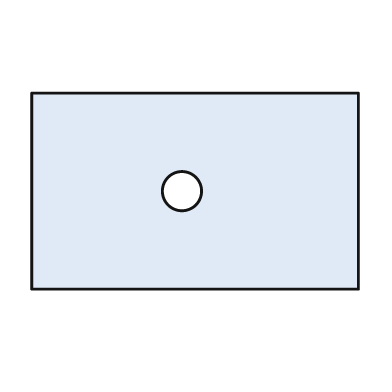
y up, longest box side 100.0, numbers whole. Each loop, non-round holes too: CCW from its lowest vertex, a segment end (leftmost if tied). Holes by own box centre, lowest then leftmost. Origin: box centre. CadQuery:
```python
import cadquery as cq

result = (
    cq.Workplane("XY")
    .moveTo(-50.0, -30.0)
    .lineTo(50.0, -30.0)
    .lineTo(50.0, 30.0)
    .lineTo(-50.0, 30.0)
    .close()
    .moveTo(-4.0, 0.0)
    .circle(6.0)
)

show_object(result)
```